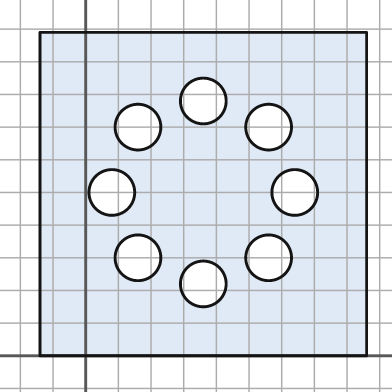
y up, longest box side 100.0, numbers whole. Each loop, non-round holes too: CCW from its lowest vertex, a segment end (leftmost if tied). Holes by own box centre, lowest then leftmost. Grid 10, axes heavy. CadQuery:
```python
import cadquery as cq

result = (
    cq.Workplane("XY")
    .moveTo(-14.0, 0.0)
    .lineTo(86.0, 0.0)
    .lineTo(86.0, 99.0)
    .lineTo(-14.0, 99.0)
    .close()
    .moveTo(36.0, 22.0)
    .circle(7.0)
    .moveTo(16.0, 30.0)
    .circle(7.0)
    .moveTo(56.0, 30.0)
    .circle(7.0)
    .moveTo(8.0, 50.0)
    .circle(7.0)
    .moveTo(64.0, 50.0)
    .circle(7.0)
    .moveTo(16.0, 70.0)
    .circle(7.0)
    .moveTo(56.0, 70.0)
    .circle(7.0)
    .moveTo(36.0, 78.0)
    .circle(7.0)
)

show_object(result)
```